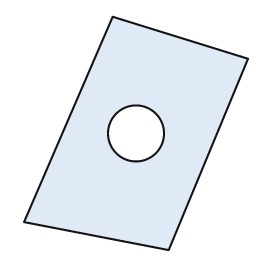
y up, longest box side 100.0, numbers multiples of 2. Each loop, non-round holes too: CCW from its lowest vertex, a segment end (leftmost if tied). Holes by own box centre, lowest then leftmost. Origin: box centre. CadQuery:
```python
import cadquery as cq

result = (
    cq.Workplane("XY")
    .moveTo(14.0, -50.0)
    .lineTo(48.0, 32.0)
    .lineTo(-10.0, 50.0)
    .lineTo(-48.0, -38.0)
    .close()
    .moveTo(0.0, 0.0)
    .circle(12.0)
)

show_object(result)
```